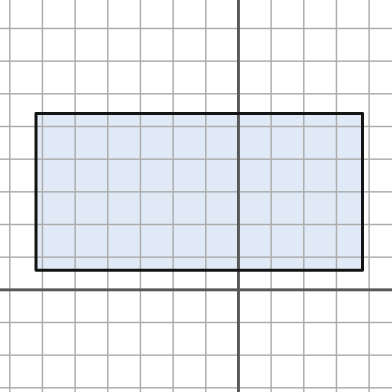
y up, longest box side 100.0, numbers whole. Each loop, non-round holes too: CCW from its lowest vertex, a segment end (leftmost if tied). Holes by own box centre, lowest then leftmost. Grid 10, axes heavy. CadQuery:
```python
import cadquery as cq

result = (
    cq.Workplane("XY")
    .moveTo(-62.0, 6.0)
    .lineTo(38.0, 6.0)
    .lineTo(38.0, 54.0)
    .lineTo(-62.0, 54.0)
    .close()
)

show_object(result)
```